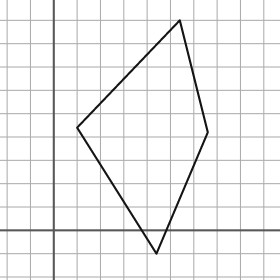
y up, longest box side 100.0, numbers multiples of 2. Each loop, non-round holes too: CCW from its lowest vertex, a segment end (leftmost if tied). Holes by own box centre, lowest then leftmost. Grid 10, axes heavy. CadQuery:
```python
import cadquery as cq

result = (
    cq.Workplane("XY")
    .moveTo(44.0, -10.0)
    .lineTo(66.0, 42.0)
    .lineTo(54.0, 90.0)
    .lineTo(10.0, 44.0)
    .close()
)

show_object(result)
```